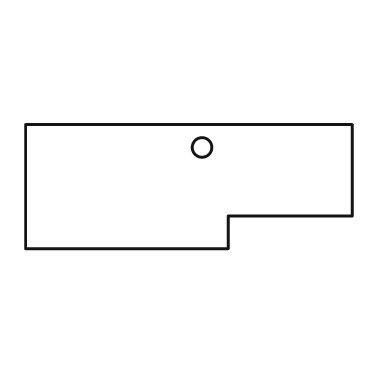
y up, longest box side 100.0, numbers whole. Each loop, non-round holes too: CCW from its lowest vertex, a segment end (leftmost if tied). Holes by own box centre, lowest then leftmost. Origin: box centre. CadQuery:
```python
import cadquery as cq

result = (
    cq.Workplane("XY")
    .moveTo(-50.0, -19.0)
    .lineTo(12.0, -19.0)
    .lineTo(12.0, -9.0)
    .lineTo(50.0, -9.0)
    .lineTo(50.0, 19.0)
    .lineTo(-50.0, 19.0)
    .close()
    .moveTo(4.0, 12.0)
    .circle(3.0)
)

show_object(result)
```